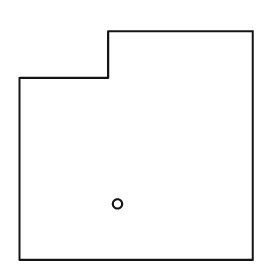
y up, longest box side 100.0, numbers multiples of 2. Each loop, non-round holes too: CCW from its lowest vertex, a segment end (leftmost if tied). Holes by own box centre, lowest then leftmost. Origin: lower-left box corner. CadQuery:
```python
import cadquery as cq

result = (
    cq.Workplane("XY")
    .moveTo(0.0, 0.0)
    .lineTo(100.0, 0.0)
    .lineTo(100.0, 98.0)
    .lineTo(38.0, 98.0)
    .lineTo(38.0, 78.0)
    .lineTo(0.0, 78.0)
    .close()
    .moveTo(42.0, 24.0)
    .circle(2.0)
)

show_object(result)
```